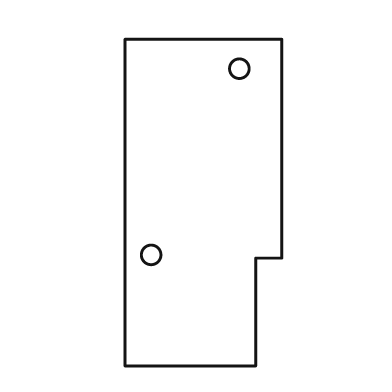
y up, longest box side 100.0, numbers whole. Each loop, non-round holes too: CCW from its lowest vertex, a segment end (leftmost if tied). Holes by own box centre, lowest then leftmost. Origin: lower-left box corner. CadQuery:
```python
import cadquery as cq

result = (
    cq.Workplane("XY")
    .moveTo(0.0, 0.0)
    .lineTo(40.0, 0.0)
    .lineTo(40.0, 33.0)
    .lineTo(48.0, 33.0)
    .lineTo(48.0, 100.0)
    .lineTo(0.0, 100.0)
    .close()
    .moveTo(8.0, 34.0)
    .circle(3.0)
    .moveTo(35.0, 91.0)
    .circle(3.0)
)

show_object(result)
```